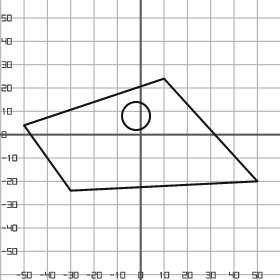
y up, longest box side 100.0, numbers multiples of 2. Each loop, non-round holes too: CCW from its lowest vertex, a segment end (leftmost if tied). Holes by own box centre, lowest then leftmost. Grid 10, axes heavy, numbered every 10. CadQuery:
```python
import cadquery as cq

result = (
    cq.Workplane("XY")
    .moveTo(-30.0, -24.0)
    .lineTo(50.0, -20.0)
    .lineTo(10.0, 24.0)
    .lineTo(-50.0, 4.0)
    .close()
    .moveTo(-2.0, 8.0)
    .circle(6.0)
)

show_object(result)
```